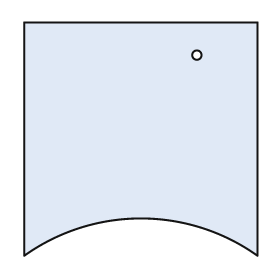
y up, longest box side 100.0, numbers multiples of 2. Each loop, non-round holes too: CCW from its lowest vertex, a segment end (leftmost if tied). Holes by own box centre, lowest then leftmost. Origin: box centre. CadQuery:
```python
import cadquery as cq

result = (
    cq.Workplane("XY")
    .moveTo(-50.0, -50.0)
    .threePointArc((0.0, -34.0), (50.0, -50.0))
    .lineTo(50.0, 50.0)
    .lineTo(-50.0, 50.0)
    .close()
    .moveTo(24.0, 36.0)
    .circle(2.0)
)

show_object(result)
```